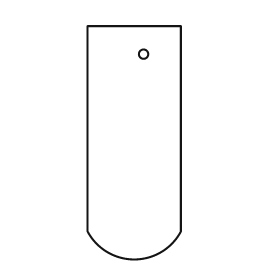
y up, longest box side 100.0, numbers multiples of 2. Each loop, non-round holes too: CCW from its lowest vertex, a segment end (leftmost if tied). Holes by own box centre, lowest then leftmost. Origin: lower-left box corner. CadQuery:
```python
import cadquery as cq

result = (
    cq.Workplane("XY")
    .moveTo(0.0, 12.0)
    .threePointArc((20.0, 0.0), (40.0, 12.0))
    .lineTo(40.0, 100.0)
    .lineTo(0.0, 100.0)
    .close()
    .moveTo(24.0, 88.0)
    .circle(2.0)
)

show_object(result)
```